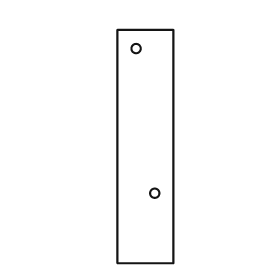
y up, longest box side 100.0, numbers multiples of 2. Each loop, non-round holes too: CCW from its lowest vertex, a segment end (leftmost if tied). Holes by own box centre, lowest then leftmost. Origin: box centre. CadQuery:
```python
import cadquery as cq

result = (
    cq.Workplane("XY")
    .moveTo(-12.0, -50.0)
    .lineTo(12.0, -50.0)
    .lineTo(12.0, 50.0)
    .lineTo(-12.0, 50.0)
    .close()
    .moveTo(4.0, -20.0)
    .circle(2.0)
    .moveTo(-4.0, 42.0)
    .circle(2.0)
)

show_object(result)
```